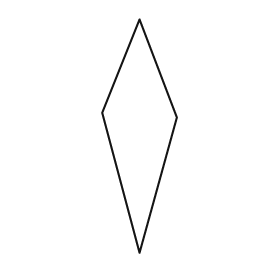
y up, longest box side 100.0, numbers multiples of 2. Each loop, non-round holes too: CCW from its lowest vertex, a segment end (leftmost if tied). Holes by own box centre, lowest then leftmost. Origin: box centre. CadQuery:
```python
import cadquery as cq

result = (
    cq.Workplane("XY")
    .moveTo(0.0, -50.0)
    .lineTo(16.0, 8.0)
    .lineTo(0.0, 50.0)
    .lineTo(-16.0, 10.0)
    .close()
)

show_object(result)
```